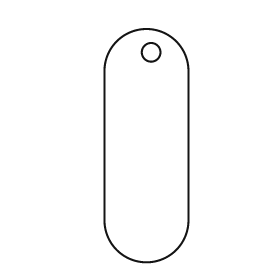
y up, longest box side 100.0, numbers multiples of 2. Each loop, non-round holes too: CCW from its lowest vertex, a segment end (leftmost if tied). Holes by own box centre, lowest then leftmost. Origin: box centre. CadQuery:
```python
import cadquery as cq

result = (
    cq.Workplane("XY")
    .moveTo(-18.0, -32.0)
    .threePointArc((0.0, -50.0), (18.0, -32.0))
    .lineTo(18.0, 32.0)
    .threePointArc((0.0, 50.0), (-18.0, 32.0))
    .close()
    .moveTo(2.0, 40.0)
    .circle(4.0)
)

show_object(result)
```